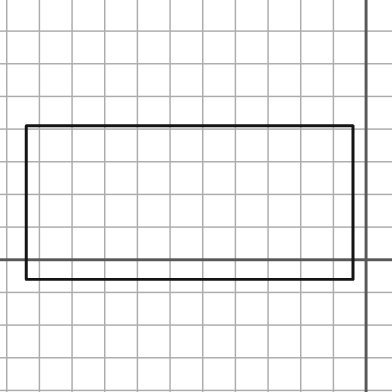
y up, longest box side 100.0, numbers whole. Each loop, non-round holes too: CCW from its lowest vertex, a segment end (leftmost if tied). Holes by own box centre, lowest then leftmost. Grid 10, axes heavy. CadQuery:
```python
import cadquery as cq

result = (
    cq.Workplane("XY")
    .moveTo(-104.0, -6.0)
    .lineTo(-4.0, -6.0)
    .lineTo(-4.0, 41.0)
    .lineTo(-104.0, 41.0)
    .close()
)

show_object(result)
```